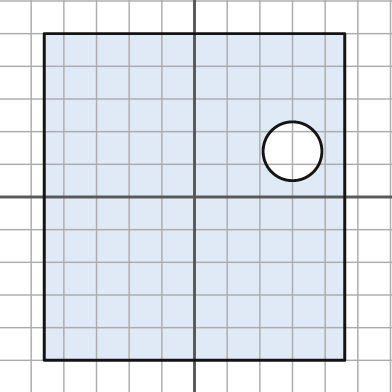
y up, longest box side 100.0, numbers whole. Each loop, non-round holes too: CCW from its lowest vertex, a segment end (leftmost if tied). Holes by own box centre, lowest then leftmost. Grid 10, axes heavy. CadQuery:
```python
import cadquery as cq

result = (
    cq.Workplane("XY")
    .moveTo(-46.0, -50.0)
    .lineTo(46.0, -50.0)
    .lineTo(46.0, 50.0)
    .lineTo(-46.0, 50.0)
    .close()
    .moveTo(30.0, 14.0)
    .circle(9.0)
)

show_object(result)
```